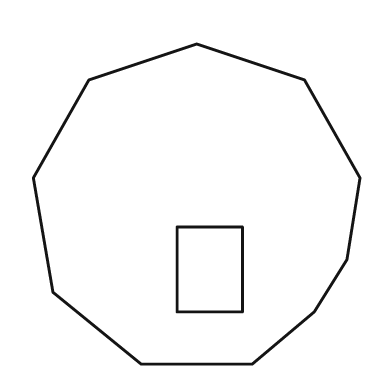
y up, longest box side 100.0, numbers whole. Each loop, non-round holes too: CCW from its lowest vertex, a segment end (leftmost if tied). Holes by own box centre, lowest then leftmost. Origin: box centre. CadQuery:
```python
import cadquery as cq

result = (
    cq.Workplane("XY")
    .moveTo(-17.0, -49.0)
    .lineTo(17.0, -49.0)
    .lineTo(36.0, -33.0)
    .lineTo(46.0, -17.0)
    .lineTo(50.0, 8.0)
    .lineTo(33.0, 38.0)
    .lineTo(0.0, 49.0)
    .lineTo(-33.0, 38.0)
    .lineTo(-50.0, 8.0)
    .lineTo(-44.0, -27.0)
    .close()
    .moveTo(-6.0, -33.0)
    .lineTo(14.0, -33.0)
    .lineTo(14.0, -7.0)
    .lineTo(-6.0, -7.0)
    .close()
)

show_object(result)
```